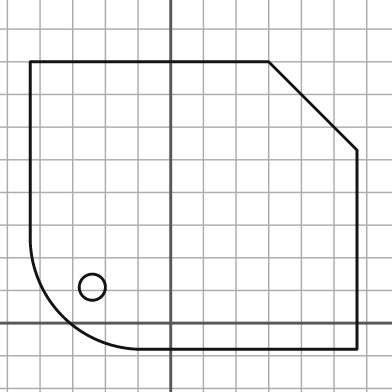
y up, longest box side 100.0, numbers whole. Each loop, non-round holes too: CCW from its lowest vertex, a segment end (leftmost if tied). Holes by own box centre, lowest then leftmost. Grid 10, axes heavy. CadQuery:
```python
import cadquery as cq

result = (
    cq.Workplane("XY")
    .moveTo(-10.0, -8.0)
    .lineTo(57.0, -8.0)
    .lineTo(57.0, 53.0)
    .lineTo(30.0, 80.0)
    .lineTo(-43.0, 80.0)
    .lineTo(-43.0, 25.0)
    .threePointArc((-33.0, 2.0), (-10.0, -8.0))
    .close()
    .moveTo(-24.0, 11.0)
    .circle(4.0)
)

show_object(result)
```